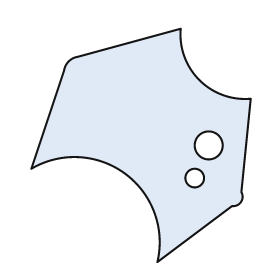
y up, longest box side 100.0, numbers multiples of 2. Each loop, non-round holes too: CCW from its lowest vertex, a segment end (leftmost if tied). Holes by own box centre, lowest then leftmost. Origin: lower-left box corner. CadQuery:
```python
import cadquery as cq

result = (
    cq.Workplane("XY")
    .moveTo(54.0, 0.0)
    .lineTo(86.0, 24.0)
    .threePointArc((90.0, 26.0), (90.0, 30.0))
    .lineTo(94.0, 70.0)
    .threePointArc((72.0, 78.0), (64.0, 100.0))
    .lineTo(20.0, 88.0)
    .threePointArc((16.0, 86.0), (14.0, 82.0))
    .lineTo(0.0, 40.0)
    .threePointArc((40.0, 38.0), (54.0, 0.0))
    .close()
    .moveTo(70.0, 36.0)
    .circle(4.0)
    .moveTo(76.0, 50.0)
    .circle(6.0)
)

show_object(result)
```